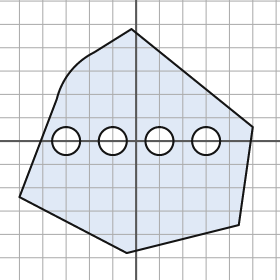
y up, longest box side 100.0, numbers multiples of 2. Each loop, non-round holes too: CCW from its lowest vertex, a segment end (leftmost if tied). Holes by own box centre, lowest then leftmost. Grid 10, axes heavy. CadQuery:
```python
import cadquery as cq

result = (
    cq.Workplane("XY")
    .moveTo(-4.0, -48.0)
    .lineTo(44.0, -36.0)
    .lineTo(50.0, 6.0)
    .lineTo(-2.0, 48.0)
    .lineTo(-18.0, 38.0)
    .threePointArc((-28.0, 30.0), (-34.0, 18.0))
    .lineTo(-50.0, -24.0)
    .close()
    .moveTo(-30.0, 0.0)
    .circle(6.0)
    .moveTo(-10.0, 0.0)
    .circle(6.0)
    .moveTo(10.0, 0.0)
    .circle(6.0)
    .moveTo(30.0, 0.0)
    .circle(6.0)
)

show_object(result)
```